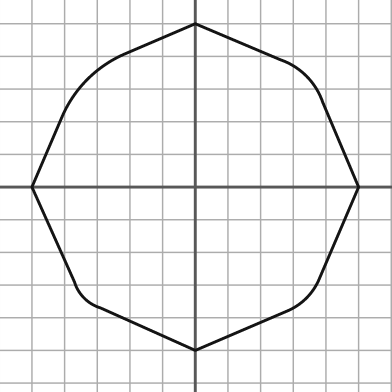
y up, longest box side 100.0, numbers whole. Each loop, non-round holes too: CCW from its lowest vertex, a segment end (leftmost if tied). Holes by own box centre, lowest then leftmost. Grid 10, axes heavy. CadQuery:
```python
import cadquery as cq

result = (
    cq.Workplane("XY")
    .moveTo(0.0, -50.0)
    .lineTo(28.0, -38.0)
    .threePointArc((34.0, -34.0), (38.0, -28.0))
    .lineTo(50.0, 0.0)
    .lineTo(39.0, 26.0)
    .threePointArc((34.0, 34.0), (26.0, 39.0))
    .lineTo(0.0, 50.0)
    .lineTo(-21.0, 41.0)
    .threePointArc((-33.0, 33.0), (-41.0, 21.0))
    .lineTo(-50.0, 0.0)
    .lineTo(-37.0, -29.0)
    .threePointArc((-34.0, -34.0), (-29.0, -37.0))
    .close()
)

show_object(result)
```